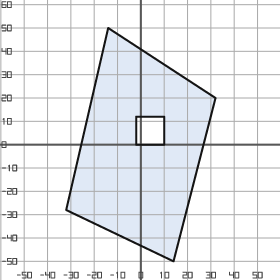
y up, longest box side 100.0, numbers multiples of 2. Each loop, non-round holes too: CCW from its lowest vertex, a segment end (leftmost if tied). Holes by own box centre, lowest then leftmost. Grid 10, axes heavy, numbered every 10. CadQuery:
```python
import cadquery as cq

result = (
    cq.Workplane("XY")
    .moveTo(14.0, -50.0)
    .lineTo(32.0, 20.0)
    .lineTo(-14.0, 50.0)
    .lineTo(-32.0, -28.0)
    .close()
    .moveTo(-2.0, 0.0)
    .lineTo(10.0, 0.0)
    .lineTo(10.0, 12.0)
    .lineTo(-2.0, 12.0)
    .close()
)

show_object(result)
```